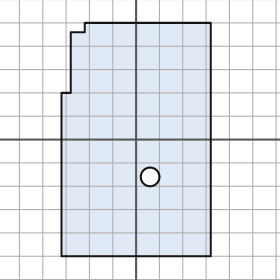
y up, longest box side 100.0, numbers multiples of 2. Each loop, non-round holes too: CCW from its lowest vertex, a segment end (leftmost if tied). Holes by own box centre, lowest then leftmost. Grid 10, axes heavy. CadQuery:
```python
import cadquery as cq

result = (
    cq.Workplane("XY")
    .moveTo(-32.0, -50.0)
    .lineTo(32.0, -50.0)
    .lineTo(32.0, 50.0)
    .lineTo(-22.0, 50.0)
    .lineTo(-22.0, 46.0)
    .lineTo(-28.0, 46.0)
    .lineTo(-28.0, 20.0)
    .lineTo(-32.0, 20.0)
    .close()
    .moveTo(6.0, -16.0)
    .circle(4.0)
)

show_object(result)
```